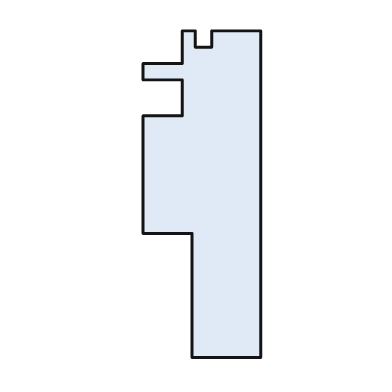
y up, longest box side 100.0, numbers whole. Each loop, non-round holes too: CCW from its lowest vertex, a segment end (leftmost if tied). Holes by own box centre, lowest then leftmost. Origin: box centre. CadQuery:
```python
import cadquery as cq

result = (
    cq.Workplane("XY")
    .moveTo(-3.0, -50.0)
    .lineTo(18.0, -50.0)
    .lineTo(18.0, 50.0)
    .lineTo(3.0, 50.0)
    .lineTo(3.0, 45.0)
    .lineTo(-2.0, 45.0)
    .lineTo(-2.0, 50.0)
    .lineTo(-6.0, 50.0)
    .lineTo(-6.0, 40.0)
    .lineTo(-18.0, 40.0)
    .lineTo(-18.0, 35.0)
    .lineTo(-6.0, 35.0)
    .lineTo(-6.0, 24.0)
    .lineTo(-18.0, 24.0)
    .lineTo(-18.0, -12.0)
    .lineTo(-3.0, -12.0)
    .close()
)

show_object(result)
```